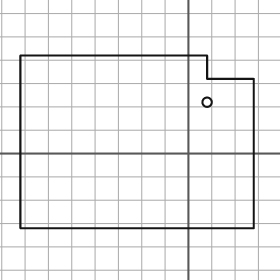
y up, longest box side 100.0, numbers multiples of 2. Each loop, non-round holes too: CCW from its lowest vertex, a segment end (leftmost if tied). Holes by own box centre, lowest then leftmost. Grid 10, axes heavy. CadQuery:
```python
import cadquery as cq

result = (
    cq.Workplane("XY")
    .moveTo(-72.0, -32.0)
    .lineTo(28.0, -32.0)
    .lineTo(28.0, 32.0)
    .lineTo(8.0, 32.0)
    .lineTo(8.0, 42.0)
    .lineTo(-72.0, 42.0)
    .close()
    .moveTo(8.0, 22.0)
    .circle(2.0)
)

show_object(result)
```